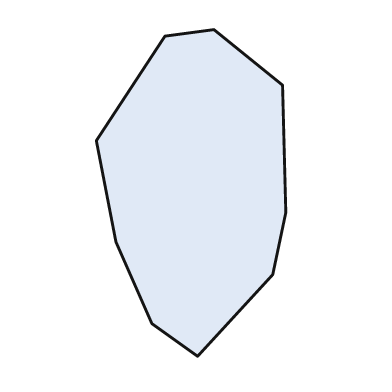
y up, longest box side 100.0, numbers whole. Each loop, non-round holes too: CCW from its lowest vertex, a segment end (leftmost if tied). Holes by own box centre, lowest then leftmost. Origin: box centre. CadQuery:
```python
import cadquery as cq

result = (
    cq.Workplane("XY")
    .moveTo(2.0, -50.0)
    .lineTo(25.0, -25.0)
    .lineTo(29.0, -6.0)
    .lineTo(28.0, 33.0)
    .lineTo(7.0, 50.0)
    .lineTo(-8.0, 48.0)
    .lineTo(-29.0, 16.0)
    .lineTo(-23.0, -15.0)
    .lineTo(-12.0, -40.0)
    .close()
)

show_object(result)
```